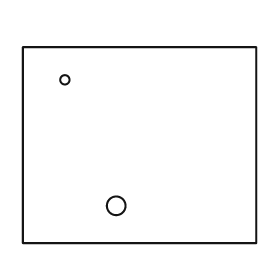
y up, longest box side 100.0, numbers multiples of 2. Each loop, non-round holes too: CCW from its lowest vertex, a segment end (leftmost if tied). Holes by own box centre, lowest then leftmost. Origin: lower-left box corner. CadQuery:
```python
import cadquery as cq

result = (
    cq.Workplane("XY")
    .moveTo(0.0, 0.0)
    .lineTo(100.0, 0.0)
    .lineTo(100.0, 84.0)
    .lineTo(0.0, 84.0)
    .close()
    .moveTo(40.0, 16.0)
    .circle(4.0)
    .moveTo(18.0, 70.0)
    .circle(2.0)
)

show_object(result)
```